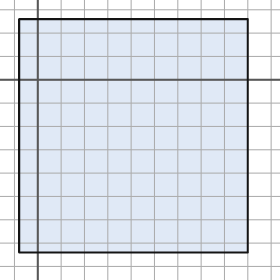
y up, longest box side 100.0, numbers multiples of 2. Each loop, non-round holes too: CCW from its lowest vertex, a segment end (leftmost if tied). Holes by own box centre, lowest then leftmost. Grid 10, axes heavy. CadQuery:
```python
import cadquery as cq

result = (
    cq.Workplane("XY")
    .moveTo(-8.0, -74.0)
    .lineTo(90.0, -74.0)
    .lineTo(90.0, 26.0)
    .lineTo(-8.0, 26.0)
    .close()
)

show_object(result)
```